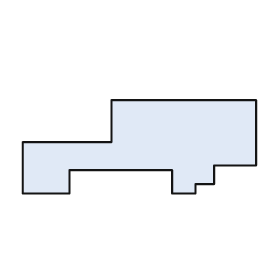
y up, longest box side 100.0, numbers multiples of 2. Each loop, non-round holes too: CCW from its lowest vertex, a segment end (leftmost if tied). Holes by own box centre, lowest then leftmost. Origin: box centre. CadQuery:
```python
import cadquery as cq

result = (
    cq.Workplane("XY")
    .moveTo(-50.0, -20.0)
    .lineTo(-30.0, -20.0)
    .lineTo(-30.0, -10.0)
    .lineTo(14.0, -10.0)
    .lineTo(14.0, -20.0)
    .lineTo(24.0, -20.0)
    .lineTo(24.0, -16.0)
    .lineTo(32.0, -16.0)
    .lineTo(32.0, -8.0)
    .lineTo(50.0, -8.0)
    .lineTo(50.0, 20.0)
    .lineTo(-12.0, 20.0)
    .lineTo(-12.0, 2.0)
    .lineTo(-50.0, 2.0)
    .close()
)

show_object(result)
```